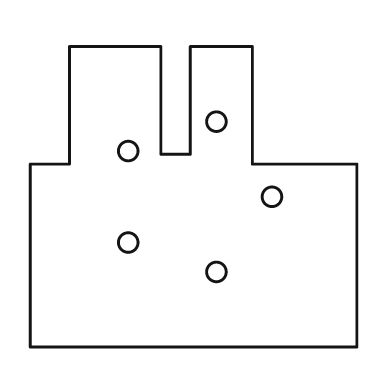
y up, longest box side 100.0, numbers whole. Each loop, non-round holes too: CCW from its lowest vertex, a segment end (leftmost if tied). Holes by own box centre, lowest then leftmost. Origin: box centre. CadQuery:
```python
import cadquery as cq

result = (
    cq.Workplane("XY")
    .moveTo(-50.0, -46.0)
    .lineTo(50.0, -46.0)
    .lineTo(50.0, 10.0)
    .lineTo(18.0, 10.0)
    .lineTo(18.0, 46.0)
    .lineTo(-1.0, 46.0)
    .lineTo(-1.0, 13.0)
    .lineTo(-10.0, 13.0)
    .lineTo(-10.0, 46.0)
    .lineTo(-38.0, 46.0)
    .lineTo(-38.0, 10.0)
    .lineTo(-50.0, 10.0)
    .close()
    .moveTo(7.0, -23.0)
    .circle(3.0)
    .moveTo(-20.0, -14.0)
    .circle(3.0)
    .moveTo(24.0, 0.0)
    .circle(3.0)
    .moveTo(-20.0, 14.0)
    .circle(3.0)
    .moveTo(7.0, 23.0)
    .circle(3.0)
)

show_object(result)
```